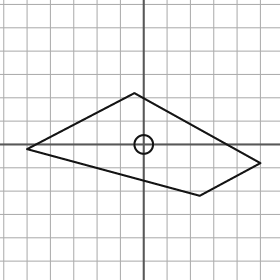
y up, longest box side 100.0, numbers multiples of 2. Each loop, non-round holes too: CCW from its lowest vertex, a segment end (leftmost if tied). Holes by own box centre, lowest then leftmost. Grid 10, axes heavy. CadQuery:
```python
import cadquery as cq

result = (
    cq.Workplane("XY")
    .moveTo(24.0, -22.0)
    .lineTo(50.0, -8.0)
    .lineTo(-4.0, 22.0)
    .lineTo(-50.0, -2.0)
    .close()
    .moveTo(0.0, 0.0)
    .circle(4.0)
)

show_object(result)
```